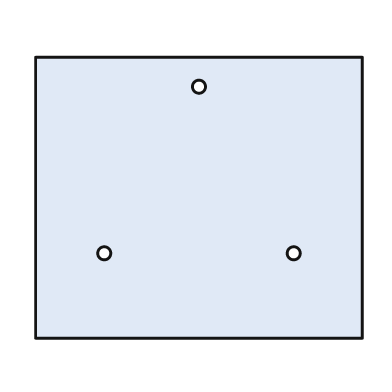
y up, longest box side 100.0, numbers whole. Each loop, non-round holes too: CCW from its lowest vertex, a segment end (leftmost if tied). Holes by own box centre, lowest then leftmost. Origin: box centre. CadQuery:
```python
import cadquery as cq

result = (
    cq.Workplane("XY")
    .moveTo(-50.0, -43.0)
    .lineTo(50.0, -43.0)
    .lineTo(50.0, 43.0)
    .lineTo(-50.0, 43.0)
    .close()
    .moveTo(-29.0, -17.0)
    .circle(2.0)
    .moveTo(29.0, -17.0)
    .circle(2.0)
    .moveTo(0.0, 34.0)
    .circle(2.0)
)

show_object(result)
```